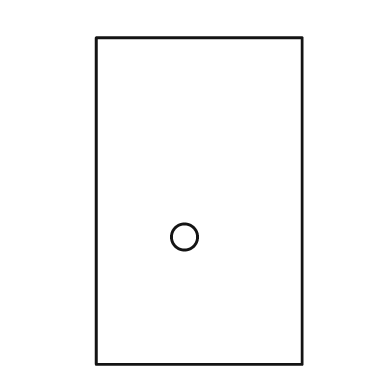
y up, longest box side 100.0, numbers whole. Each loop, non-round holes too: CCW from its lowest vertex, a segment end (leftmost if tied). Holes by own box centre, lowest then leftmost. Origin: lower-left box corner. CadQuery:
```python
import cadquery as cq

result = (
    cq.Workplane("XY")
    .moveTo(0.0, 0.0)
    .lineTo(63.0, 0.0)
    .lineTo(63.0, 100.0)
    .lineTo(0.0, 100.0)
    .close()
    .moveTo(27.0, 39.0)
    .circle(4.0)
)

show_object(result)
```